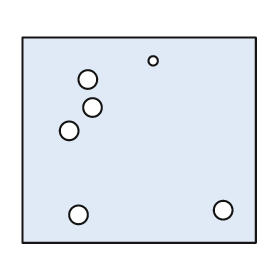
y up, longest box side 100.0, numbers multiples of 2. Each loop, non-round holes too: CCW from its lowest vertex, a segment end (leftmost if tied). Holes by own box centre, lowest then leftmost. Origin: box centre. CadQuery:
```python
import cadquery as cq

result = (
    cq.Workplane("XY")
    .moveTo(-50.0, -44.0)
    .lineTo(50.0, -44.0)
    .lineTo(50.0, 44.0)
    .lineTo(-50.0, 44.0)
    .close()
    .moveTo(-26.0, -32.0)
    .circle(4.0)
    .moveTo(36.0, -30.0)
    .circle(4.0)
    .moveTo(-30.0, 4.0)
    .circle(4.0)
    .moveTo(-20.0, 14.0)
    .circle(4.0)
    .moveTo(-22.0, 26.0)
    .circle(4.0)
    .moveTo(6.0, 34.0)
    .circle(2.0)
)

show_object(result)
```